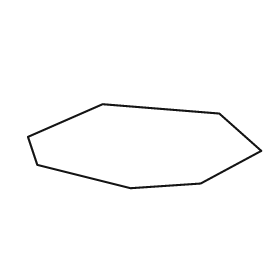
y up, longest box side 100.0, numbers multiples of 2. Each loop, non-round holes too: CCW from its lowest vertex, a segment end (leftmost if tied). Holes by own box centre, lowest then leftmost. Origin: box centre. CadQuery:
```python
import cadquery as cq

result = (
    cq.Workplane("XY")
    .moveTo(-6.0, -18.0)
    .lineTo(24.0, -16.0)
    .lineTo(50.0, -2.0)
    .lineTo(32.0, 14.0)
    .lineTo(-18.0, 18.0)
    .lineTo(-50.0, 4.0)
    .lineTo(-46.0, -8.0)
    .close()
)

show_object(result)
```